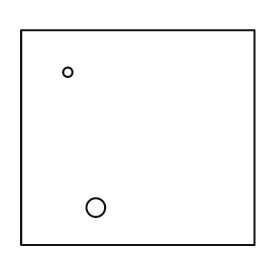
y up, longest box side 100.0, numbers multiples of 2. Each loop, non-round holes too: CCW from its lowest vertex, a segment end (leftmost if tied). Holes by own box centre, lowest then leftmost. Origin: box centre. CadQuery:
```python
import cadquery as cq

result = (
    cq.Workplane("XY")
    .moveTo(-50.0, -46.0)
    .lineTo(50.0, -46.0)
    .lineTo(50.0, 46.0)
    .lineTo(-50.0, 46.0)
    .close()
    .moveTo(-18.0, -30.0)
    .circle(4.0)
    .moveTo(-30.0, 28.0)
    .circle(2.0)
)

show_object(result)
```